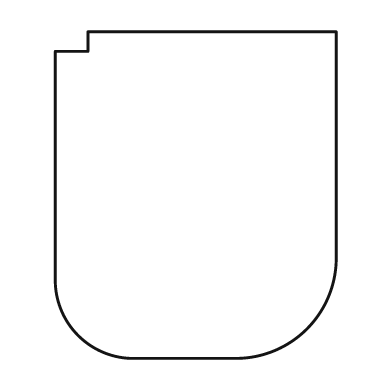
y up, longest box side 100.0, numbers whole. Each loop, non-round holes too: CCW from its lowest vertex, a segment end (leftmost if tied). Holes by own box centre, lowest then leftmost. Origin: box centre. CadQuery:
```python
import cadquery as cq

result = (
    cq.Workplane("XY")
    .moveTo(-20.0, -50.0)
    .lineTo(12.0, -50.0)
    .threePointArc((34.0, -41.0), (43.0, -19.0))
    .lineTo(43.0, 50.0)
    .lineTo(-33.0, 50.0)
    .lineTo(-33.0, 44.0)
    .lineTo(-43.0, 44.0)
    .lineTo(-43.0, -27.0)
    .threePointArc((-36.0, -43.0), (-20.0, -50.0))
    .close()
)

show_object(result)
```